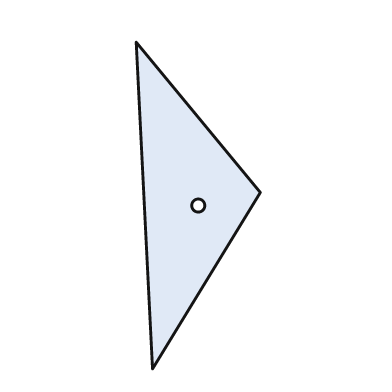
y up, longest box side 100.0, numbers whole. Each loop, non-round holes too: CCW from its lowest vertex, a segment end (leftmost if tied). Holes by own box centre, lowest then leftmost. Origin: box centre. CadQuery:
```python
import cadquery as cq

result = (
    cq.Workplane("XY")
    .moveTo(-14.0, -50.0)
    .lineTo(19.0, 4.0)
    .lineTo(-19.0, 50.0)
    .close()
    .moveTo(0.0, 0.0)
    .circle(2.0)
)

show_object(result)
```